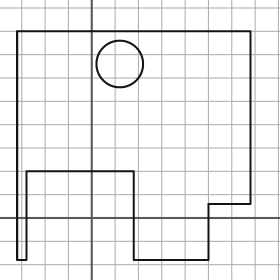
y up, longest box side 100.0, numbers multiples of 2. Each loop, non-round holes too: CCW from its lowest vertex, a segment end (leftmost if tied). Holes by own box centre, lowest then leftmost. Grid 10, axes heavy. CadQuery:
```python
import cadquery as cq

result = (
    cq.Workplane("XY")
    .moveTo(-32.0, -18.0)
    .lineTo(-28.0, -18.0)
    .lineTo(-28.0, 20.0)
    .lineTo(18.0, 20.0)
    .lineTo(18.0, -18.0)
    .lineTo(50.0, -18.0)
    .lineTo(50.0, 6.0)
    .lineTo(68.0, 6.0)
    .lineTo(68.0, 80.0)
    .lineTo(-32.0, 80.0)
    .close()
    .moveTo(12.0, 66.0)
    .circle(10.0)
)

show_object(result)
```